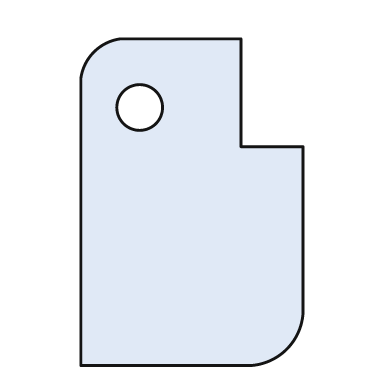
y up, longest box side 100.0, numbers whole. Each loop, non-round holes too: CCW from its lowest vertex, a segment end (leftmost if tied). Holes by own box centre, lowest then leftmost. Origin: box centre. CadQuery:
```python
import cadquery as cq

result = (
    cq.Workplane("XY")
    .moveTo(-34.0, -50.0)
    .lineTo(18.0, -50.0)
    .threePointArc((29.0, -45.0), (34.0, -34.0))
    .lineTo(34.0, 17.0)
    .lineTo(15.0, 17.0)
    .lineTo(15.0, 50.0)
    .lineTo(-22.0, 50.0)
    .threePointArc((-30.0, 46.0), (-34.0, 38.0))
    .close()
    .moveTo(-16.0, 29.0)
    .circle(7.0)
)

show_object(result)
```